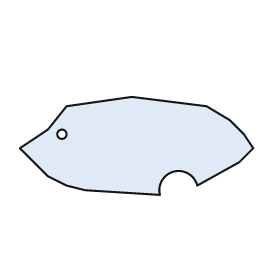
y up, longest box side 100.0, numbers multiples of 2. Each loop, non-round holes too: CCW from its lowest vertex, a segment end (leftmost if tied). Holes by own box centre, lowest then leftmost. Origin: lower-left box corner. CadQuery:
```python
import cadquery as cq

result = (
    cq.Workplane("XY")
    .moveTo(60.0, 0.0)
    .threePointArc((66.0, 10.0), (76.0, 4.0))
    .lineTo(94.0, 14.0)
    .lineTo(100.0, 20.0)
    .lineTo(96.0, 26.0)
    .lineTo(90.0, 32.0)
    .lineTo(80.0, 38.0)
    .lineTo(48.0, 42.0)
    .lineTo(20.0, 38.0)
    .lineTo(12.0, 28.0)
    .lineTo(0.0, 20.0)
    .lineTo(12.0, 8.0)
    .lineTo(20.0, 4.0)
    .lineTo(28.0, 2.0)
    .close()
    .moveTo(18.0, 26.0)
    .circle(2.0)
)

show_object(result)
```